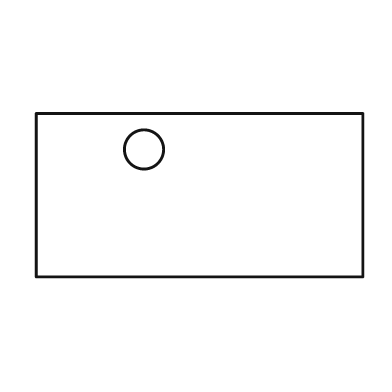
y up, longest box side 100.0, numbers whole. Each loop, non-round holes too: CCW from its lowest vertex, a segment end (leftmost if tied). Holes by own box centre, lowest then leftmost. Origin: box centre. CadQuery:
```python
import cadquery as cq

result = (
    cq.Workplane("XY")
    .moveTo(-50.0, -25.0)
    .lineTo(50.0, -25.0)
    .lineTo(50.0, 25.0)
    .lineTo(-50.0, 25.0)
    .close()
    .moveTo(-17.0, 14.0)
    .circle(6.0)
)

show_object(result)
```